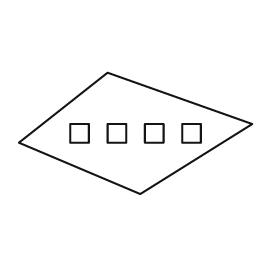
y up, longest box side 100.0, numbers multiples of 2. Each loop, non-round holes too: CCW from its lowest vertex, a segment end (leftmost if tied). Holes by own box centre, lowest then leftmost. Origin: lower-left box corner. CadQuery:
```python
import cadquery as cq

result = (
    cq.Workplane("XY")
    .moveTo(52.0, 0.0)
    .lineTo(100.0, 30.0)
    .lineTo(38.0, 52.0)
    .lineTo(0.0, 22.0)
    .close()
    .moveTo(22.0, 22.0)
    .lineTo(30.0, 22.0)
    .lineTo(30.0, 30.0)
    .lineTo(22.0, 30.0)
    .close()
    .moveTo(38.0, 22.0)
    .lineTo(46.0, 22.0)
    .lineTo(46.0, 30.0)
    .lineTo(38.0, 30.0)
    .close()
    .moveTo(54.0, 22.0)
    .lineTo(62.0, 22.0)
    .lineTo(62.0, 30.0)
    .lineTo(54.0, 30.0)
    .close()
    .moveTo(70.0, 22.0)
    .lineTo(78.0, 22.0)
    .lineTo(78.0, 30.0)
    .lineTo(70.0, 30.0)
    .close()
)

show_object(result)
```